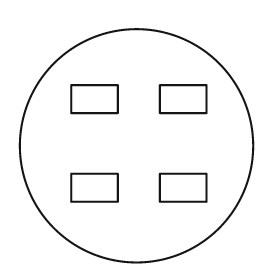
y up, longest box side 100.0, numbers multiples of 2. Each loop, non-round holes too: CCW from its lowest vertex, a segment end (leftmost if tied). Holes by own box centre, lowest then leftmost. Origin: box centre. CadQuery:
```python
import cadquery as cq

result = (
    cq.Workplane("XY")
    .moveTo(0.0, 0.0)
    .circle(50.0)
    .moveTo(-28.0, -24.0)
    .lineTo(-8.0, -24.0)
    .lineTo(-8.0, -12.0)
    .lineTo(-28.0, -12.0)
    .close()
    .moveTo(10.0, -24.0)
    .lineTo(30.0, -24.0)
    .lineTo(30.0, -12.0)
    .lineTo(10.0, -12.0)
    .close()
    .moveTo(-28.0, 14.0)
    .lineTo(-8.0, 14.0)
    .lineTo(-8.0, 26.0)
    .lineTo(-28.0, 26.0)
    .close()
    .moveTo(10.0, 14.0)
    .lineTo(30.0, 14.0)
    .lineTo(30.0, 26.0)
    .lineTo(10.0, 26.0)
    .close()
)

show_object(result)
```